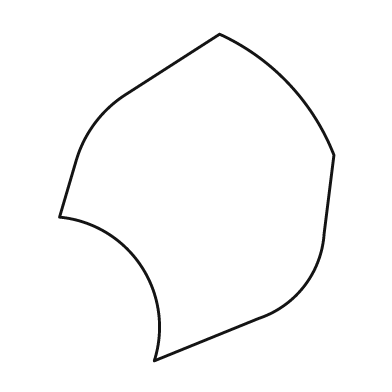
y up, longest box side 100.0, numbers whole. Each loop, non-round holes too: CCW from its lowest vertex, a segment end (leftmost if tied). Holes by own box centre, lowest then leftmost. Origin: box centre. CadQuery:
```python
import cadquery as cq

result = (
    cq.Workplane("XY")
    .moveTo(-13.0, -50.0)
    .lineTo(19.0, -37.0)
    .threePointArc((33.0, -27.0), (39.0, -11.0))
    .lineTo(42.0, 13.0)
    .threePointArc((28.0, 35.0), (7.0, 50.0))
    .lineTo(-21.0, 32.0)
    .threePointArc((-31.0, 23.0), (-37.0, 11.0))
    .lineTo(-42.0, -6.0)
    .threePointArc((-17.0, -21.0), (-13.0, -50.0))
    .close()
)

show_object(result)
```